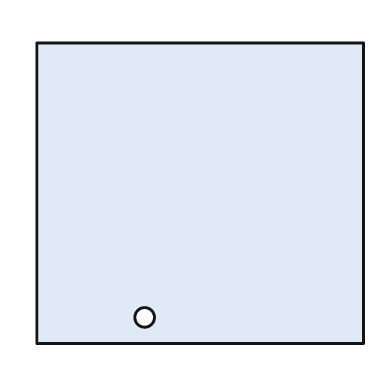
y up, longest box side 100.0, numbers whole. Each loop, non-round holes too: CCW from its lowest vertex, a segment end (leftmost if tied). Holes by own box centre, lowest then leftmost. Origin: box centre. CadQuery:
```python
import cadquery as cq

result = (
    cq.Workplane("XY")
    .moveTo(-50.0, -46.0)
    .lineTo(50.0, -46.0)
    .lineTo(50.0, 46.0)
    .lineTo(-50.0, 46.0)
    .close()
    .moveTo(-17.0, -38.0)
    .circle(3.0)
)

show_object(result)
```